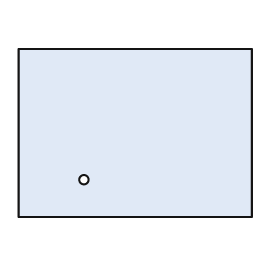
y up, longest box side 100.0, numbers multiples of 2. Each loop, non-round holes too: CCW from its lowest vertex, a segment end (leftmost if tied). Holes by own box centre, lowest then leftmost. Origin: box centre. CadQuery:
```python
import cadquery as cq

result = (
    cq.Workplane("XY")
    .moveTo(-50.0, -36.0)
    .lineTo(50.0, -36.0)
    .lineTo(50.0, 36.0)
    .lineTo(-50.0, 36.0)
    .close()
    .moveTo(-22.0, -20.0)
    .circle(2.0)
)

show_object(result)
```